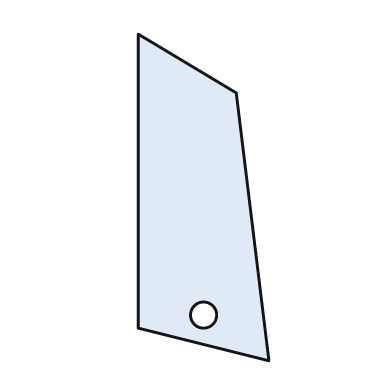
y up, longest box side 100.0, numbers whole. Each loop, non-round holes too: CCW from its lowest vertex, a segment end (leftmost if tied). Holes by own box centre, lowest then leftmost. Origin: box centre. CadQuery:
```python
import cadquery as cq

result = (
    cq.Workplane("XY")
    .moveTo(20.0, -50.0)
    .lineTo(10.0, 32.0)
    .lineTo(-20.0, 50.0)
    .lineTo(-20.0, -40.0)
    .close()
    .moveTo(0.0, -36.0)
    .circle(4.0)
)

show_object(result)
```